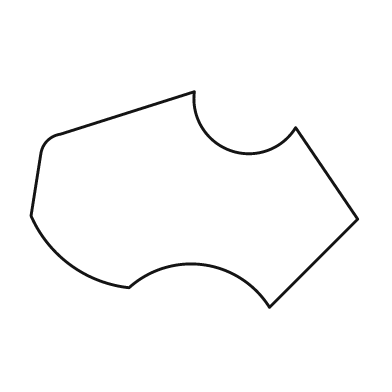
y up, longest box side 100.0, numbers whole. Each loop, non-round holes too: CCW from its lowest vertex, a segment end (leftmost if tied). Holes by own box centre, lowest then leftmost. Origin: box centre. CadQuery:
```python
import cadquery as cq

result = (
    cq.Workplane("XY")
    .moveTo(23.0, -33.0)
    .lineTo(50.0, -6.0)
    .lineTo(31.0, 22.0)
    .threePointArc((11.0, 15.0), (0.0, 33.0))
    .lineTo(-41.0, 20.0)
    .threePointArc((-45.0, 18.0), (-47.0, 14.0))
    .lineTo(-50.0, -5.0)
    .threePointArc((-38.0, -20.0), (-20.0, -27.0))
    .threePointArc((3.0, -20.0), (23.0, -33.0))
    .close()
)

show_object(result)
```